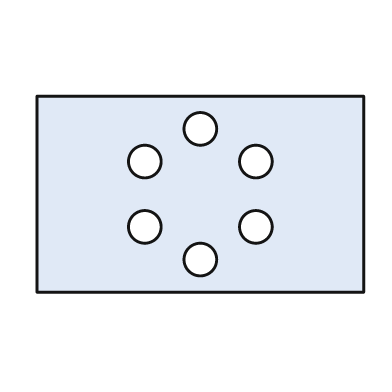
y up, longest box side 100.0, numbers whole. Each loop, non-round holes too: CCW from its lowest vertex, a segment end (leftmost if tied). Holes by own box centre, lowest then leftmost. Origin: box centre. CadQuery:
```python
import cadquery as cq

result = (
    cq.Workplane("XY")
    .moveTo(-50.0, -30.0)
    .lineTo(50.0, -30.0)
    .lineTo(50.0, 30.0)
    .lineTo(-50.0, 30.0)
    .close()
    .moveTo(0.0, -20.0)
    .circle(5.0)
    .moveTo(-17.0, -10.0)
    .circle(5.0)
    .moveTo(17.0, -10.0)
    .circle(5.0)
    .moveTo(-17.0, 10.0)
    .circle(5.0)
    .moveTo(17.0, 10.0)
    .circle(5.0)
    .moveTo(0.0, 20.0)
    .circle(5.0)
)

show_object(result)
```